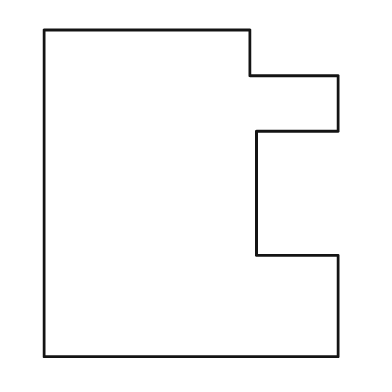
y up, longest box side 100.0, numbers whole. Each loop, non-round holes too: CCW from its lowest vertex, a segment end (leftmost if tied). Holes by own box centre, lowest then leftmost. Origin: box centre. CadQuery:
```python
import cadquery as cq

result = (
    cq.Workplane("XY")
    .moveTo(-45.0, -50.0)
    .lineTo(45.0, -50.0)
    .lineTo(45.0, -19.0)
    .lineTo(20.0, -19.0)
    .lineTo(20.0, 19.0)
    .lineTo(45.0, 19.0)
    .lineTo(45.0, 36.0)
    .lineTo(18.0, 36.0)
    .lineTo(18.0, 50.0)
    .lineTo(-45.0, 50.0)
    .close()
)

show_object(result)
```